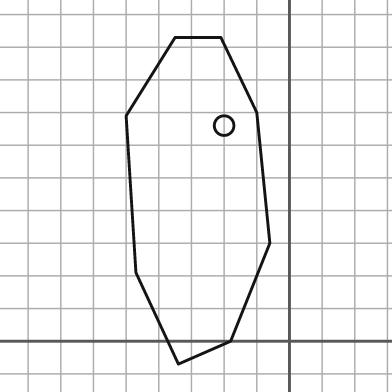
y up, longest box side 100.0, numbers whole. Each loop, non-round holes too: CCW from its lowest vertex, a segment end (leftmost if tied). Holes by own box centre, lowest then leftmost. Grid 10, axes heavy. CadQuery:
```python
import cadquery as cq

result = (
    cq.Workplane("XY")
    .moveTo(-34.0, -7.0)
    .lineTo(-18.0, 0.0)
    .lineTo(-6.0, 30.0)
    .lineTo(-10.0, 70.0)
    .lineTo(-21.0, 93.0)
    .lineTo(-35.0, 93.0)
    .lineTo(-50.0, 69.0)
    .lineTo(-47.0, 21.0)
    .close()
    .moveTo(-20.0, 66.0)
    .circle(3.0)
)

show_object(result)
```